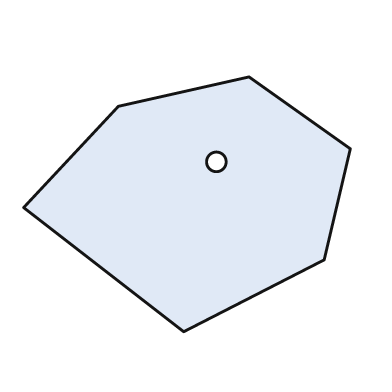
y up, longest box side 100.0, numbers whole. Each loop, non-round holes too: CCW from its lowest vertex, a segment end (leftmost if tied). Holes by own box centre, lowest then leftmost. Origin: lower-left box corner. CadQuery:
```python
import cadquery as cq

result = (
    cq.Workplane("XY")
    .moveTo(49.0, 0.0)
    .lineTo(92.0, 22.0)
    .lineTo(100.0, 56.0)
    .lineTo(69.0, 78.0)
    .lineTo(29.0, 69.0)
    .lineTo(0.0, 38.0)
    .close()
    .moveTo(59.0, 52.0)
    .circle(3.0)
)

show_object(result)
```